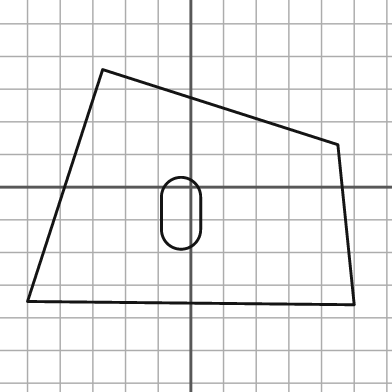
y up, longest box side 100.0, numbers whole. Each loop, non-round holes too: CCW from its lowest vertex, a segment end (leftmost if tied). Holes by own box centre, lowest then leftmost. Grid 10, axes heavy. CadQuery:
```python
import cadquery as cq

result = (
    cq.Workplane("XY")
    .moveTo(50.0, -36.0)
    .lineTo(45.0, 13.0)
    .lineTo(-27.0, 36.0)
    .lineTo(-50.0, -35.0)
    .close()
    .moveTo(-9.0, -13.0)
    .threePointArc((-3.0, -19.0), (3.0, -13.0))
    .lineTo(3.0, -3.0)
    .threePointArc((-3.0, 3.0), (-9.0, -3.0))
    .close()
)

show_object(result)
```